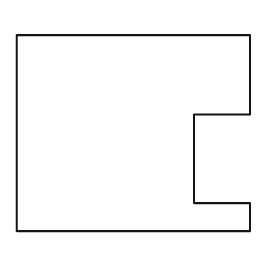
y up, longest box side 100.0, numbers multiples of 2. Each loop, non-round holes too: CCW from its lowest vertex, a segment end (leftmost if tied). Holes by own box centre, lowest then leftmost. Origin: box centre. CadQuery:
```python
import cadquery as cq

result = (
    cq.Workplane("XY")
    .moveTo(-50.0, -42.0)
    .lineTo(50.0, -42.0)
    .lineTo(50.0, -30.0)
    .lineTo(26.0, -30.0)
    .lineTo(26.0, 8.0)
    .lineTo(50.0, 8.0)
    .lineTo(50.0, 42.0)
    .lineTo(-50.0, 42.0)
    .close()
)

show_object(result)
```